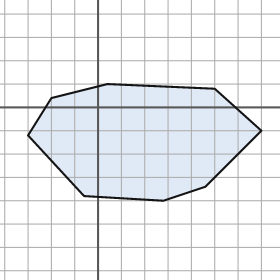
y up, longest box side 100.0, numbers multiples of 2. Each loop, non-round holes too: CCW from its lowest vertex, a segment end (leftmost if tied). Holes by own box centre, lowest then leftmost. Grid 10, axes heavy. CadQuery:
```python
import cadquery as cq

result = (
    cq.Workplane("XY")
    .moveTo(28.0, -40.0)
    .lineTo(46.0, -34.0)
    .lineTo(70.0, -10.0)
    .lineTo(50.0, 8.0)
    .lineTo(4.0, 10.0)
    .lineTo(-20.0, 4.0)
    .lineTo(-30.0, -12.0)
    .lineTo(-6.0, -38.0)
    .close()
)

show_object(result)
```